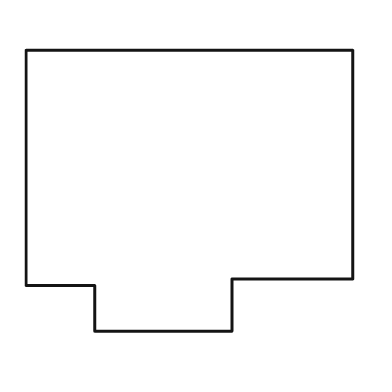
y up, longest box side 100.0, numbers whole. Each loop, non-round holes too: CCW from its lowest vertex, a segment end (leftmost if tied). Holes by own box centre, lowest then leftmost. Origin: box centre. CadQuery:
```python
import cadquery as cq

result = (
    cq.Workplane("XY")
    .moveTo(-29.0, -43.0)
    .lineTo(13.0, -43.0)
    .lineTo(13.0, -27.0)
    .lineTo(50.0, -27.0)
    .lineTo(50.0, 43.0)
    .lineTo(-50.0, 43.0)
    .lineTo(-50.0, -29.0)
    .lineTo(-29.0, -29.0)
    .close()
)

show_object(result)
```